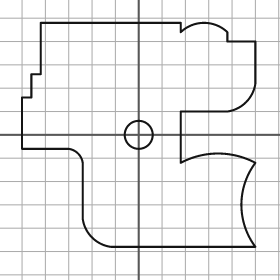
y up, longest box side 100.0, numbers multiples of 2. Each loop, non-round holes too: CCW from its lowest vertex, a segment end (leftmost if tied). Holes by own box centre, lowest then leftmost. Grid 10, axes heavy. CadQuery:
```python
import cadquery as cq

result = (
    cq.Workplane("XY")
    .moveTo(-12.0, -48.0)
    .lineTo(50.0, -48.0)
    .threePointArc((44.0, -30.0), (50.0, -12.0))
    .threePointArc((34.0, -8.0), (18.0, -12.0))
    .lineTo(18.0, 10.0)
    .lineTo(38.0, 10.0)
    .threePointArc((46.0, 14.0), (50.0, 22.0))
    .lineTo(50.0, 40.0)
    .lineTo(38.0, 40.0)
    .lineTo(38.0, 44.0)
    .threePointArc((28.0, 48.0), (18.0, 44.0))
    .lineTo(18.0, 48.0)
    .lineTo(-42.0, 48.0)
    .lineTo(-42.0, 26.0)
    .lineTo(-46.0, 26.0)
    .lineTo(-46.0, 16.0)
    .lineTo(-50.0, 16.0)
    .lineTo(-50.0, -6.0)
    .lineTo(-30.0, -6.0)
    .threePointArc((-26.0, -8.0), (-24.0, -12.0))
    .lineTo(-24.0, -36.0)
    .threePointArc((-20.0, -44.0), (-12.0, -48.0))
    .close()
    .moveTo(0.0, 0.0)
    .circle(6.0)
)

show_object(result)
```